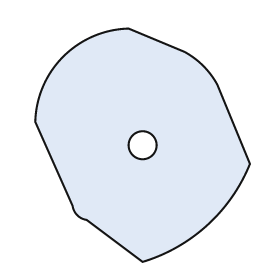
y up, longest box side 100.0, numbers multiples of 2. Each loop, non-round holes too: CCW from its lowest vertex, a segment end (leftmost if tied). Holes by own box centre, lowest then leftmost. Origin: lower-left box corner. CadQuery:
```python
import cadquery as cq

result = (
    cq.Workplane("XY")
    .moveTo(46.0, 0.0)
    .threePointArc((74.0, 16.0), (92.0, 42.0))
    .lineTo(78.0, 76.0)
    .threePointArc((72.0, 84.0), (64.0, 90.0))
    .lineTo(40.0, 100.0)
    .threePointArc((12.0, 88.0), (0.0, 60.0))
    .lineTo(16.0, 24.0)
    .threePointArc((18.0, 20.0), (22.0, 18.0))
    .close()
    .moveTo(46.0, 50.0)
    .circle(6.0)
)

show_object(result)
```